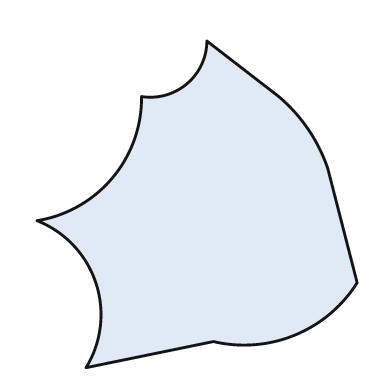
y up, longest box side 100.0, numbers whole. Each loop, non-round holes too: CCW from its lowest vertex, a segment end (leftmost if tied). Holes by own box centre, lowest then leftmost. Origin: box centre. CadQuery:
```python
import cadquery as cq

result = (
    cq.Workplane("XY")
    .moveTo(-34.0, -50.0)
    .lineTo(5.0, -42.0)
    .threePointArc((30.0, -40.0), (49.0, -24.0))
    .lineTo(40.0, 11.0)
    .threePointArc((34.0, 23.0), (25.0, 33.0))
    .lineTo(3.0, 50.0)
    .threePointArc((-3.0, 37.0), (-17.0, 33.0))
    .threePointArc((-26.0, 8.0), (-49.0, -5.0))
    .threePointArc((-31.0, -24.0), (-34.0, -50.0))
    .close()
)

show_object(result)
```